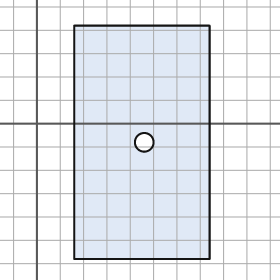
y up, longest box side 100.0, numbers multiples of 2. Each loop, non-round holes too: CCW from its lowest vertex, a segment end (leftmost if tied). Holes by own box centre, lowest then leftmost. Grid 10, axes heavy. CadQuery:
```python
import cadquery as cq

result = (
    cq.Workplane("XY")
    .moveTo(16.0, -58.0)
    .lineTo(74.0, -58.0)
    .lineTo(74.0, 42.0)
    .lineTo(16.0, 42.0)
    .close()
    .moveTo(46.0, -8.0)
    .circle(4.0)
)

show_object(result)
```